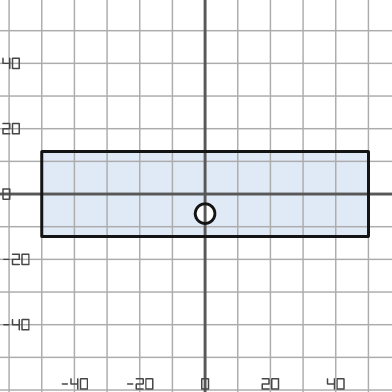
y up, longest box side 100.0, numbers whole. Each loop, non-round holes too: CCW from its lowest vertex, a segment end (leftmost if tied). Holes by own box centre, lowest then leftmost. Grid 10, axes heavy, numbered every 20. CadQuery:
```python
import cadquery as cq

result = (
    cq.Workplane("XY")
    .moveTo(-50.0, -13.0)
    .lineTo(50.0, -13.0)
    .lineTo(50.0, 13.0)
    .lineTo(-50.0, 13.0)
    .close()
    .moveTo(0.0, -6.0)
    .circle(3.0)
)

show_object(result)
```